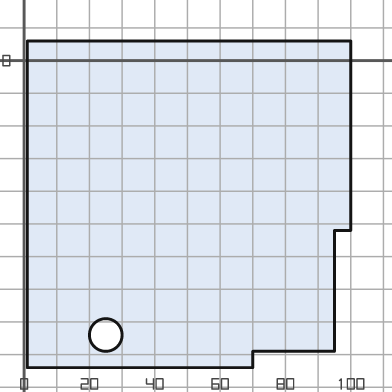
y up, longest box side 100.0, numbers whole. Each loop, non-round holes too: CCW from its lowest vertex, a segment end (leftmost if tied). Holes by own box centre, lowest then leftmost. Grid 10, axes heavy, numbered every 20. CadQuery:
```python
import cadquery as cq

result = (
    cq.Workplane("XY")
    .moveTo(1.0, -94.0)
    .lineTo(70.0, -94.0)
    .lineTo(70.0, -89.0)
    .lineTo(95.0, -89.0)
    .lineTo(95.0, -52.0)
    .lineTo(100.0, -52.0)
    .lineTo(100.0, 6.0)
    .lineTo(1.0, 6.0)
    .close()
    .moveTo(25.0, -84.0)
    .circle(5.0)
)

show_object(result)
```